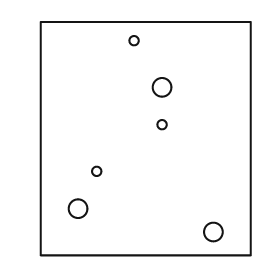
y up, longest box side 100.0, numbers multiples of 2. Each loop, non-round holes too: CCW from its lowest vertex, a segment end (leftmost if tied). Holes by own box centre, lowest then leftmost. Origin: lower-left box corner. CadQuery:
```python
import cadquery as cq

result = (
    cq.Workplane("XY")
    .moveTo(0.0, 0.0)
    .lineTo(90.0, 0.0)
    .lineTo(90.0, 100.0)
    .lineTo(0.0, 100.0)
    .close()
    .moveTo(74.0, 10.0)
    .circle(4.0)
    .moveTo(16.0, 20.0)
    .circle(4.0)
    .moveTo(24.0, 36.0)
    .circle(2.0)
    .moveTo(52.0, 56.0)
    .circle(2.0)
    .moveTo(52.0, 72.0)
    .circle(4.0)
    .moveTo(40.0, 92.0)
    .circle(2.0)
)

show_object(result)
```